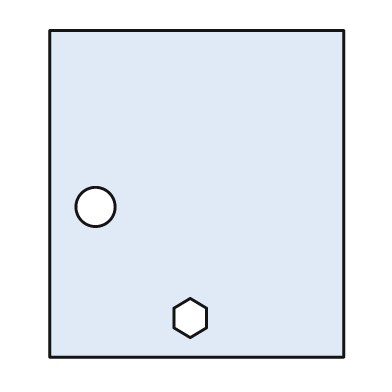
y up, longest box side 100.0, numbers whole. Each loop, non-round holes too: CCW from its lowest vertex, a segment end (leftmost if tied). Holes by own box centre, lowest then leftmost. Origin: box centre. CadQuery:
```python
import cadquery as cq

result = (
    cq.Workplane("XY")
    .moveTo(-45.0, -50.0)
    .lineTo(45.0, -50.0)
    .lineTo(45.0, 50.0)
    .lineTo(-45.0, 50.0)
    .close()
    .moveTo(-2.0, -44.0)
    .lineTo(3.0, -41.0)
    .lineTo(3.0, -35.0)
    .lineTo(-2.0, -32.0)
    .lineTo(-7.0, -35.0)
    .lineTo(-7.0, -41.0)
    .close()
    .moveTo(-31.0, -4.0)
    .circle(6.0)
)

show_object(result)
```